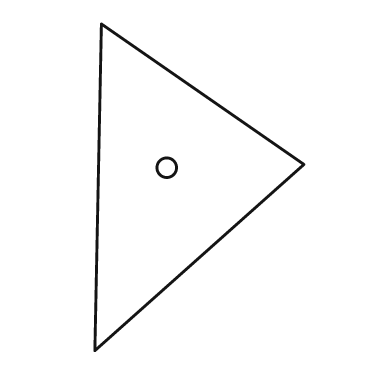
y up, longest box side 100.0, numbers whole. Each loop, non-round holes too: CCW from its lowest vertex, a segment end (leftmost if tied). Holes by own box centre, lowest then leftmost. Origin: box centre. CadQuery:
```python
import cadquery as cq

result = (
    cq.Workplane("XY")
    .moveTo(-32.0, -50.0)
    .lineTo(32.0, 7.0)
    .lineTo(-30.0, 50.0)
    .close()
    .moveTo(-10.0, 6.0)
    .circle(3.0)
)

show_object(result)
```